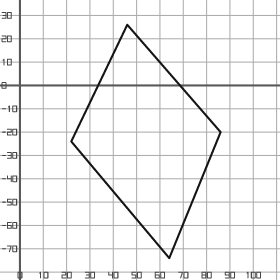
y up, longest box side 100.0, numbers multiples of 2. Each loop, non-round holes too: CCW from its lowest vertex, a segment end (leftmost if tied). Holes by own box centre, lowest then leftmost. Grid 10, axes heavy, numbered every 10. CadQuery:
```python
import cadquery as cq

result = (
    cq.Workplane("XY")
    .moveTo(64.0, -74.0)
    .lineTo(86.0, -20.0)
    .lineTo(46.0, 26.0)
    .lineTo(22.0, -24.0)
    .close()
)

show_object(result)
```